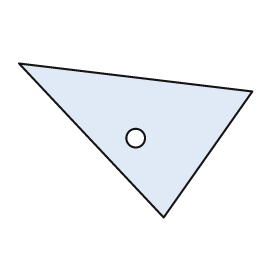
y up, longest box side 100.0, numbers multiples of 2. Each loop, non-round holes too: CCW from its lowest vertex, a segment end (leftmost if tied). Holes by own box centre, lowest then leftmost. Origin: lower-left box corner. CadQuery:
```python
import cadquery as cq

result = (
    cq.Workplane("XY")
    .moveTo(62.0, 0.0)
    .lineTo(100.0, 54.0)
    .lineTo(0.0, 66.0)
    .close()
    .moveTo(50.0, 34.0)
    .circle(4.0)
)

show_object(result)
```